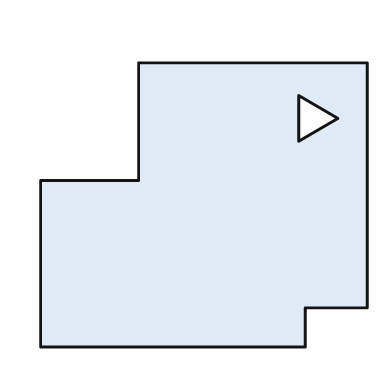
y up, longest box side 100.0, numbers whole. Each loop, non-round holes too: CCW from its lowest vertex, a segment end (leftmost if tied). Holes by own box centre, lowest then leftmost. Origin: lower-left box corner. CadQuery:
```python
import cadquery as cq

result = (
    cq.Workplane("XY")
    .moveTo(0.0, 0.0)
    .lineTo(81.0, 0.0)
    .lineTo(81.0, 12.0)
    .lineTo(100.0, 12.0)
    .lineTo(100.0, 87.0)
    .lineTo(30.0, 87.0)
    .lineTo(30.0, 51.0)
    .lineTo(0.0, 51.0)
    .close()
    .moveTo(79.0, 63.0)
    .lineTo(91.0, 70.0)
    .lineTo(79.0, 77.0)
    .close()
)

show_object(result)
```